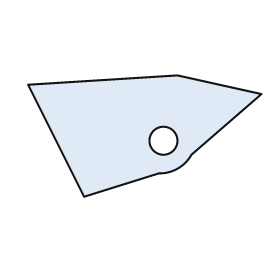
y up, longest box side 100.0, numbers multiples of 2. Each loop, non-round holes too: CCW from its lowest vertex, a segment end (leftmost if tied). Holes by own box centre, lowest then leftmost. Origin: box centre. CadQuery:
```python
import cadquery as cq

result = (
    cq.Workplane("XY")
    .moveTo(-26.0, -26.0)
    .lineTo(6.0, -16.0)
    .threePointArc((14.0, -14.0), (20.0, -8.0))
    .lineTo(50.0, 18.0)
    .lineTo(14.0, 26.0)
    .lineTo(-50.0, 22.0)
    .close()
    .moveTo(8.0, -2.0)
    .circle(6.0)
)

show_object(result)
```